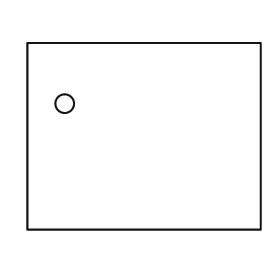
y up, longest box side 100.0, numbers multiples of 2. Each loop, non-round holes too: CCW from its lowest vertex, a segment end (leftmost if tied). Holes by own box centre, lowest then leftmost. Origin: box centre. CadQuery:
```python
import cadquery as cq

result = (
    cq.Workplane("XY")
    .moveTo(-50.0, -40.0)
    .lineTo(50.0, -40.0)
    .lineTo(50.0, 40.0)
    .lineTo(-50.0, 40.0)
    .close()
    .moveTo(-34.0, 14.0)
    .circle(4.0)
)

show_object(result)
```